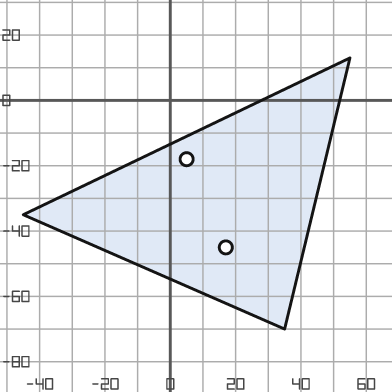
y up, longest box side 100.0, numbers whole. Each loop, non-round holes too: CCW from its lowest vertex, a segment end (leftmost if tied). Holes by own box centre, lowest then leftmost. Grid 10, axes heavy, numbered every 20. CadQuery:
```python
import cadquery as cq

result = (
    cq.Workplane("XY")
    .moveTo(35.0, -70.0)
    .lineTo(55.0, 13.0)
    .lineTo(-45.0, -35.0)
    .close()
    .moveTo(17.0, -45.0)
    .circle(2.0)
    .moveTo(5.0, -18.0)
    .circle(2.0)
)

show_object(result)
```